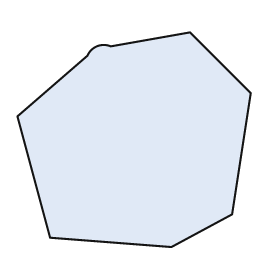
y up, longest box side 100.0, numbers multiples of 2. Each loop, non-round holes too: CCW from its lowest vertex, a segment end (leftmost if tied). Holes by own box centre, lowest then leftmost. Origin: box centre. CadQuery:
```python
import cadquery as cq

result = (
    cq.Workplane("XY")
    .moveTo(16.0, -46.0)
    .lineTo(42.0, -32.0)
    .lineTo(50.0, 20.0)
    .lineTo(24.0, 46.0)
    .lineTo(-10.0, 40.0)
    .threePointArc((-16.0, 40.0), (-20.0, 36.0))
    .lineTo(-50.0, 10.0)
    .lineTo(-36.0, -42.0)
    .close()
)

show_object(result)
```